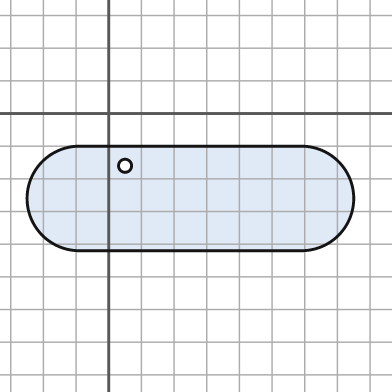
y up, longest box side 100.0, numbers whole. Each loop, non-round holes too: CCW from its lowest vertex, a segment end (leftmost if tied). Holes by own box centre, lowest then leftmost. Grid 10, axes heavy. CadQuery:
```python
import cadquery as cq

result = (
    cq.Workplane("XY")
    .moveTo(-9.0, -42.0)
    .lineTo(59.0, -42.0)
    .threePointArc((75.0, -26.0), (59.0, -10.0))
    .lineTo(-9.0, -10.0)
    .threePointArc((-25.0, -26.0), (-9.0, -42.0))
    .close()
    .moveTo(5.0, -16.0)
    .circle(2.0)
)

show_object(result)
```